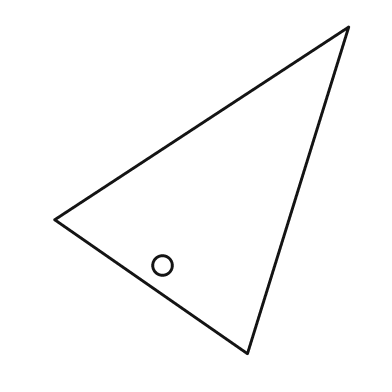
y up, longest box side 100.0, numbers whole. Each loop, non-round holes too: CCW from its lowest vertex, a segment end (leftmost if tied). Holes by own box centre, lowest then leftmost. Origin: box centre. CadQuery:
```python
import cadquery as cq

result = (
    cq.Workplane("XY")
    .moveTo(14.0, -50.0)
    .lineTo(45.0, 50.0)
    .lineTo(-45.0, -9.0)
    .close()
    .moveTo(-12.0, -23.0)
    .circle(3.0)
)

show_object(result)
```